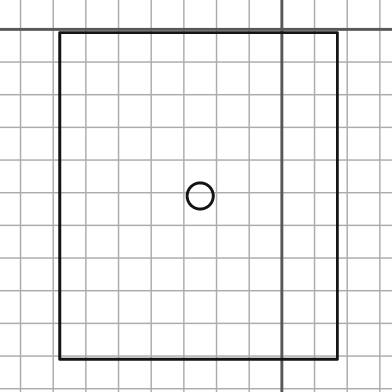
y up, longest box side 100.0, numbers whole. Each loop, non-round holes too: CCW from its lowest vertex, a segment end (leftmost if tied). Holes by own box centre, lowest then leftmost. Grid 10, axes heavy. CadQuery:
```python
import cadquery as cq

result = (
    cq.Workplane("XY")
    .moveTo(-68.0, -101.0)
    .lineTo(17.0, -101.0)
    .lineTo(17.0, -1.0)
    .lineTo(-68.0, -1.0)
    .close()
    .moveTo(-25.0, -51.0)
    .circle(4.0)
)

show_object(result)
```